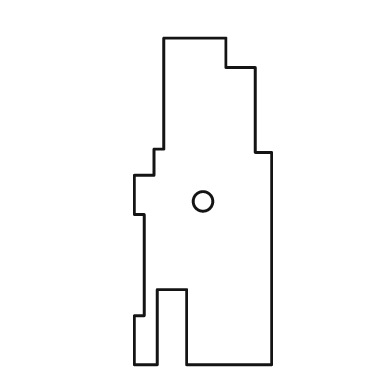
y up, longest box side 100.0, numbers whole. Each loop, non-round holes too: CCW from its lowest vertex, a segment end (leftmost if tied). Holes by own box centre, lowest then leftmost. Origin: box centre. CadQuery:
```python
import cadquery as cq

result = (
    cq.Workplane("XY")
    .moveTo(-21.0, -50.0)
    .lineTo(-14.0, -50.0)
    .lineTo(-14.0, -27.0)
    .lineTo(-5.0, -27.0)
    .lineTo(-5.0, -50.0)
    .lineTo(21.0, -50.0)
    .lineTo(21.0, 15.0)
    .lineTo(16.0, 15.0)
    .lineTo(16.0, 41.0)
    .lineTo(7.0, 41.0)
    .lineTo(7.0, 50.0)
    .lineTo(-12.0, 50.0)
    .lineTo(-12.0, 16.0)
    .lineTo(-15.0, 16.0)
    .lineTo(-15.0, 8.0)
    .lineTo(-21.0, 8.0)
    .lineTo(-21.0, -4.0)
    .lineTo(-18.0, -4.0)
    .lineTo(-18.0, -35.0)
    .lineTo(-21.0, -35.0)
    .close()
    .moveTo(0.0, 0.0)
    .circle(3.0)
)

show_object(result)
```